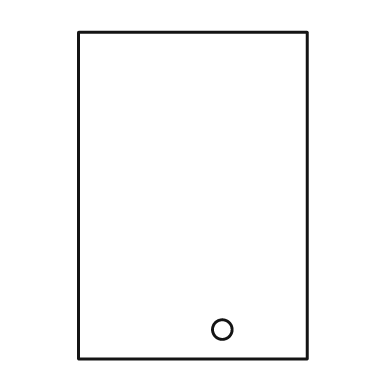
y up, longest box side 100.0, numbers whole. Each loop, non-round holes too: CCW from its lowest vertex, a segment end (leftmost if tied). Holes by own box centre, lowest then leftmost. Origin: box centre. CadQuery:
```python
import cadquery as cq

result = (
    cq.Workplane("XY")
    .moveTo(-35.0, -50.0)
    .lineTo(35.0, -50.0)
    .lineTo(35.0, 50.0)
    .lineTo(-35.0, 50.0)
    .close()
    .moveTo(9.0, -41.0)
    .circle(3.0)
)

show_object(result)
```